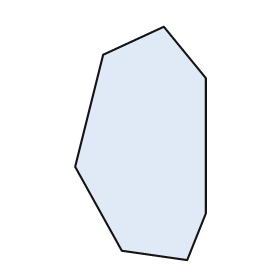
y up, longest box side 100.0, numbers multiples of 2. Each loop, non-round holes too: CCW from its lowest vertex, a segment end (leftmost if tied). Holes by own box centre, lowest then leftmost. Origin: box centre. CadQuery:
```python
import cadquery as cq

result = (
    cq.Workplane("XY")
    .moveTo(20.0, -50.0)
    .lineTo(28.0, -30.0)
    .lineTo(28.0, 28.0)
    .lineTo(10.0, 50.0)
    .lineTo(-16.0, 38.0)
    .lineTo(-28.0, -10.0)
    .lineTo(-8.0, -46.0)
    .close()
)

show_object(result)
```